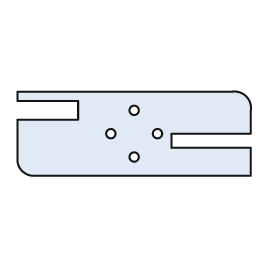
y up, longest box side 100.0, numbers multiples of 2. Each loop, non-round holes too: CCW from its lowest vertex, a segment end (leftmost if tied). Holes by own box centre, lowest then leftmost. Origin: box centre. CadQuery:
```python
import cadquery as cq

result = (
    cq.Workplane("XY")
    .moveTo(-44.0, -18.0)
    .lineTo(50.0, -18.0)
    .lineTo(50.0, -6.0)
    .lineTo(16.0, -6.0)
    .lineTo(16.0, 0.0)
    .lineTo(50.0, 0.0)
    .lineTo(50.0, 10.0)
    .threePointArc((48.0, 16.0), (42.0, 18.0))
    .lineTo(-50.0, 18.0)
    .lineTo(-50.0, 14.0)
    .lineTo(-24.0, 14.0)
    .lineTo(-24.0, 6.0)
    .lineTo(-50.0, 6.0)
    .lineTo(-50.0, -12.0)
    .threePointArc((-48.0, -16.0), (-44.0, -18.0))
    .close()
    .moveTo(0.0, -10.0)
    .circle(2.0)
    .moveTo(-10.0, 0.0)
    .circle(2.0)
    .moveTo(10.0, 0.0)
    .circle(2.0)
    .moveTo(0.0, 10.0)
    .circle(2.0)
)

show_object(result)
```